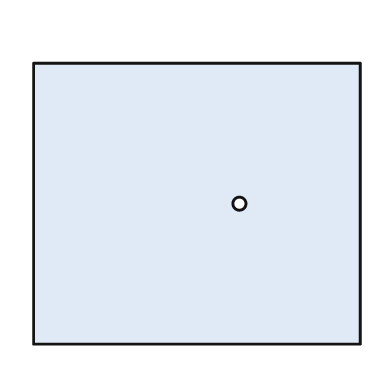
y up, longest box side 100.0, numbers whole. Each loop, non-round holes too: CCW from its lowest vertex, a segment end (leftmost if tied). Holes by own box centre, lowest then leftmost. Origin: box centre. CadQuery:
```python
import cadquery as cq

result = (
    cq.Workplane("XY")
    .moveTo(-50.0, -43.0)
    .lineTo(50.0, -43.0)
    .lineTo(50.0, 43.0)
    .lineTo(-50.0, 43.0)
    .close()
    .moveTo(13.0, 0.0)
    .circle(2.0)
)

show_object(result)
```